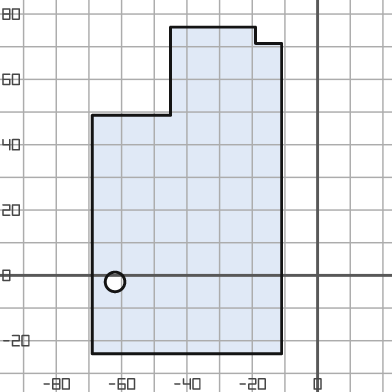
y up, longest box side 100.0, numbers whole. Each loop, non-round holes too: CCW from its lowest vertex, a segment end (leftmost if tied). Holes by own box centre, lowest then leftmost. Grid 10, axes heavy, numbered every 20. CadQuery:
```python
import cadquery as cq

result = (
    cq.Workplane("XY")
    .moveTo(-69.0, -24.0)
    .lineTo(-11.0, -24.0)
    .lineTo(-11.0, 71.0)
    .lineTo(-19.0, 71.0)
    .lineTo(-19.0, 76.0)
    .lineTo(-45.0, 76.0)
    .lineTo(-45.0, 49.0)
    .lineTo(-69.0, 49.0)
    .close()
    .moveTo(-62.0, -2.0)
    .circle(3.0)
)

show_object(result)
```